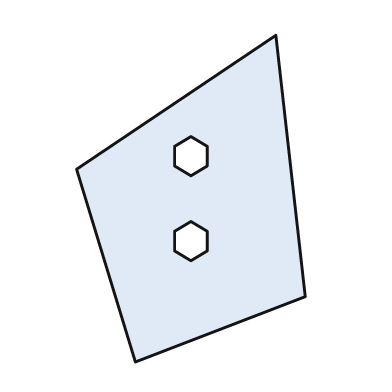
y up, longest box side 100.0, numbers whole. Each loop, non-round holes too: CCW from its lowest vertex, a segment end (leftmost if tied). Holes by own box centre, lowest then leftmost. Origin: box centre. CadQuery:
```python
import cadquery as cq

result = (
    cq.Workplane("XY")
    .moveTo(-17.0, -50.0)
    .lineTo(35.0, -30.0)
    .lineTo(26.0, 50.0)
    .lineTo(-35.0, 9.0)
    .close()
    .moveTo(0.0, -19.0)
    .lineTo(5.0, -16.0)
    .lineTo(5.0, -10.0)
    .lineTo(0.0, -7.0)
    .lineTo(-5.0, -10.0)
    .lineTo(-5.0, -16.0)
    .close()
    .moveTo(0.0, 7.0)
    .lineTo(5.0, 10.0)
    .lineTo(5.0, 16.0)
    .lineTo(0.0, 19.0)
    .lineTo(-5.0, 16.0)
    .lineTo(-5.0, 10.0)
    .close()
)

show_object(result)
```